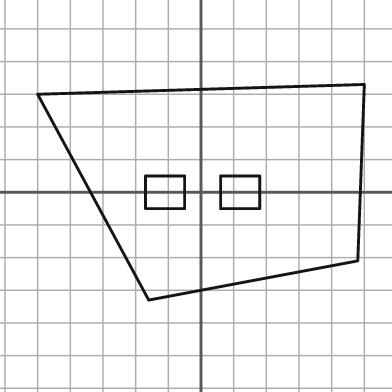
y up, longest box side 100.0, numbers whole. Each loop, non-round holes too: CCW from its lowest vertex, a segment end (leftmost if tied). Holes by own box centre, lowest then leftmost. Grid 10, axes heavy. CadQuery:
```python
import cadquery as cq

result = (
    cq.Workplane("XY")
    .moveTo(-16.0, -33.0)
    .lineTo(48.0, -21.0)
    .lineTo(50.0, 33.0)
    .lineTo(-50.0, 30.0)
    .close()
    .moveTo(-17.0, -5.0)
    .lineTo(-5.0, -5.0)
    .lineTo(-5.0, 5.0)
    .lineTo(-17.0, 5.0)
    .close()
    .moveTo(6.0, -5.0)
    .lineTo(18.0, -5.0)
    .lineTo(18.0, 5.0)
    .lineTo(6.0, 5.0)
    .close()
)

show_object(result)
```